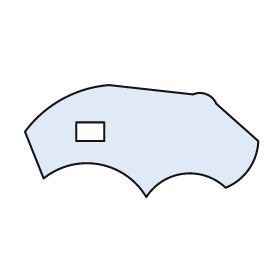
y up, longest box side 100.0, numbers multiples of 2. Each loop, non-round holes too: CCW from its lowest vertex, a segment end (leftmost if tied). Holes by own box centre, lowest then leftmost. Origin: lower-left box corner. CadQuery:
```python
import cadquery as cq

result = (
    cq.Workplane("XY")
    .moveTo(52.0, 0.0)
    .threePointArc((68.0, 10.0), (86.0, 4.0))
    .threePointArc((96.0, 12.0), (100.0, 24.0))
    .lineTo(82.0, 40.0)
    .threePointArc((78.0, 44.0), (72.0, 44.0))
    .lineTo(36.0, 48.0)
    .threePointArc((16.0, 42.0), (0.0, 28.0))
    .lineTo(8.0, 8.0)
    .threePointArc((32.0, 14.0), (52.0, 0.0))
    .close()
    .moveTo(22.0, 24.0)
    .lineTo(34.0, 24.0)
    .lineTo(34.0, 32.0)
    .lineTo(22.0, 32.0)
    .close()
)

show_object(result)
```